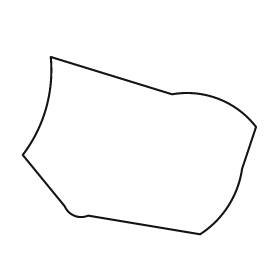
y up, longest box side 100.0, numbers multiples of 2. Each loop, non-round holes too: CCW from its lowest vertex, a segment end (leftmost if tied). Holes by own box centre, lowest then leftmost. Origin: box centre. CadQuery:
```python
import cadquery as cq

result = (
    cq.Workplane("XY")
    .moveTo(26.0, -38.0)
    .threePointArc((38.0, -26.0), (44.0, -10.0))
    .lineTo(50.0, 8.0)
    .threePointArc((34.0, 20.0), (14.0, 22.0))
    .lineTo(-38.0, 38.0)
    .threePointArc((-40.0, 16.0), (-50.0, -4.0))
    .lineTo(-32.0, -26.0)
    .threePointArc((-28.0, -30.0), (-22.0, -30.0))
    .close()
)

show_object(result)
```